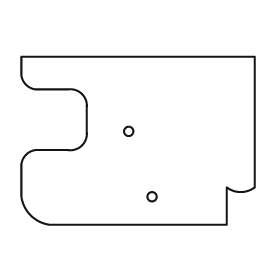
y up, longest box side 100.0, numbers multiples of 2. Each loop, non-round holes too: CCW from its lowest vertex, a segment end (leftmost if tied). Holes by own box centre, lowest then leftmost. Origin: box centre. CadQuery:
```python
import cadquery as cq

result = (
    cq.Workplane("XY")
    .moveTo(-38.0, -36.0)
    .lineTo(38.0, -36.0)
    .lineTo(38.0, -20.0)
    .threePointArc((44.0, -22.0), (50.0, -20.0))
    .lineTo(50.0, 36.0)
    .lineTo(-50.0, 36.0)
    .lineTo(-50.0, 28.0)
    .threePointArc((-48.0, 24.0), (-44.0, 22.0))
    .lineTo(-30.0, 22.0)
    .threePointArc((-24.0, 20.0), (-22.0, 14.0))
    .lineTo(-22.0, 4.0)
    .threePointArc((-24.0, -2.0), (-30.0, -4.0))
    .lineTo(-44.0, -4.0)
    .threePointArc((-48.0, -6.0), (-50.0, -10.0))
    .lineTo(-50.0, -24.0)
    .threePointArc((-46.0, -32.0), (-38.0, -36.0))
    .close()
    .moveTo(6.0, -24.0)
    .circle(2.0)
    .moveTo(-4.0, 4.0)
    .circle(2.0)
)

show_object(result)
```